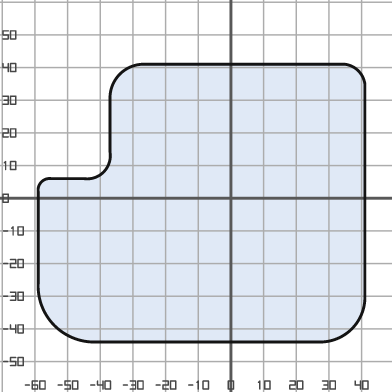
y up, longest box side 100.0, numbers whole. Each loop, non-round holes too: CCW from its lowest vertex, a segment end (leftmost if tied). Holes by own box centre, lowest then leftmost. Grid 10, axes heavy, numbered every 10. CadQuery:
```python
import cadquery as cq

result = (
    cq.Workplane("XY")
    .moveTo(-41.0, -44.0)
    .lineTo(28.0, -44.0)
    .threePointArc((37.0, -40.0), (41.0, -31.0))
    .lineTo(41.0, 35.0)
    .threePointArc((39.0, 39.0), (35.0, 41.0))
    .lineTo(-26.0, 41.0)
    .threePointArc((-34.0, 38.0), (-37.0, 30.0))
    .lineTo(-37.0, 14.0)
    .threePointArc((-39.0, 8.0), (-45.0, 6.0))
    .lineTo(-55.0, 6.0)
    .threePointArc((-58.0, 5.0), (-59.0, 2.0))
    .lineTo(-59.0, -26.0)
    .threePointArc((-54.0, -39.0), (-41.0, -44.0))
    .close()
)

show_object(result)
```